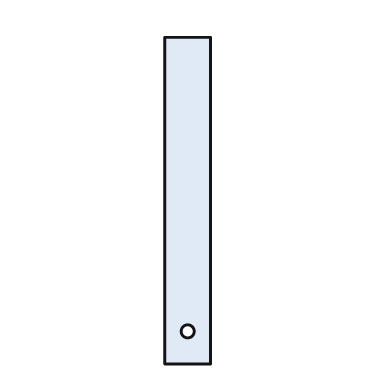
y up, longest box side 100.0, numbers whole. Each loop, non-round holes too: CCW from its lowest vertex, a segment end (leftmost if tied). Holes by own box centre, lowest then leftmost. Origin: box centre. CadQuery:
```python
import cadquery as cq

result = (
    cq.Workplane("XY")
    .moveTo(-7.0, -50.0)
    .lineTo(7.0, -50.0)
    .lineTo(7.0, 50.0)
    .lineTo(-7.0, 50.0)
    .close()
    .moveTo(0.0, -40.0)
    .circle(2.0)
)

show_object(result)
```